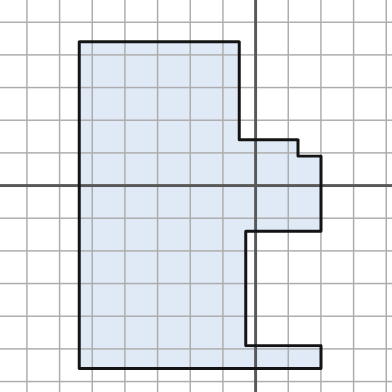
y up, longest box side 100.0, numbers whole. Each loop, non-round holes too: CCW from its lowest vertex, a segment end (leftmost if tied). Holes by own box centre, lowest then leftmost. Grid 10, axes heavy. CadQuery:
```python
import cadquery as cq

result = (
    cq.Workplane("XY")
    .moveTo(-54.0, -56.0)
    .lineTo(20.0, -56.0)
    .lineTo(20.0, -49.0)
    .lineTo(-3.0, -49.0)
    .lineTo(-3.0, -14.0)
    .lineTo(20.0, -14.0)
    .lineTo(20.0, 9.0)
    .lineTo(13.0, 9.0)
    .lineTo(13.0, 14.0)
    .lineTo(-5.0, 14.0)
    .lineTo(-5.0, 44.0)
    .lineTo(-54.0, 44.0)
    .close()
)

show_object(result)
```